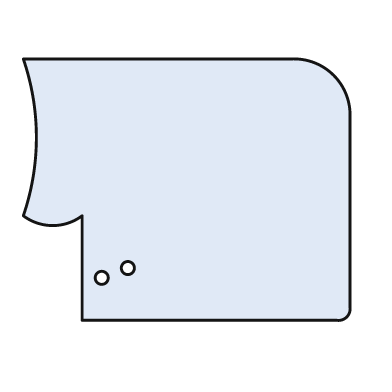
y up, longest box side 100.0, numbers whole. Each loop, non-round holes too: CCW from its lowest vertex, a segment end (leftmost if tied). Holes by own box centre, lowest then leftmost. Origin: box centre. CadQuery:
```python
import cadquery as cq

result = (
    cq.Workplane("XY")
    .moveTo(-32.0, -40.0)
    .lineTo(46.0, -40.0)
    .threePointArc((49.0, -39.0), (50.0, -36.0))
    .lineTo(50.0, 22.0)
    .threePointArc((45.0, 35.0), (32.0, 40.0))
    .lineTo(-50.0, 40.0)
    .threePointArc((-46.0, 16.0), (-50.0, -8.0))
    .threePointArc((-41.0, -11.0), (-32.0, -8.0))
    .close()
    .moveTo(-26.0, -27.0)
    .circle(2.0)
    .moveTo(-18.0, -24.0)
    .circle(2.0)
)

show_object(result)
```